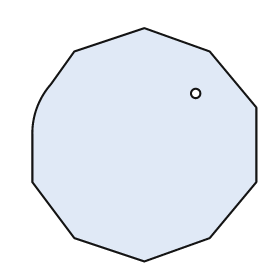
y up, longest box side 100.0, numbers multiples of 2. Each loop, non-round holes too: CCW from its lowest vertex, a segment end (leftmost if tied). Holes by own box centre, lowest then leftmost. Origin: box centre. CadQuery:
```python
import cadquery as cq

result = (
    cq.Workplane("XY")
    .moveTo(0.0, -50.0)
    .lineTo(28.0, -40.0)
    .lineTo(48.0, -16.0)
    .lineTo(48.0, 16.0)
    .lineTo(28.0, 40.0)
    .lineTo(0.0, 50.0)
    .lineTo(-30.0, 40.0)
    .lineTo(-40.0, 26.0)
    .threePointArc((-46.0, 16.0), (-48.0, 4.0))
    .lineTo(-48.0, -16.0)
    .lineTo(-30.0, -40.0)
    .close()
    .moveTo(22.0, 22.0)
    .circle(2.0)
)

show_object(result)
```